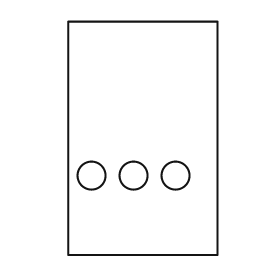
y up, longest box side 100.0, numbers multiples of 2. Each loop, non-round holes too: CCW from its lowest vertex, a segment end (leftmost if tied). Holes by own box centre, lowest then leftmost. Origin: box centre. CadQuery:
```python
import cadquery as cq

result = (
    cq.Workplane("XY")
    .moveTo(-32.0, -50.0)
    .lineTo(32.0, -50.0)
    .lineTo(32.0, 50.0)
    .lineTo(-32.0, 50.0)
    .close()
    .moveTo(-22.0, -16.0)
    .circle(6.0)
    .moveTo(-4.0, -16.0)
    .circle(6.0)
    .moveTo(14.0, -16.0)
    .circle(6.0)
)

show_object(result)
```